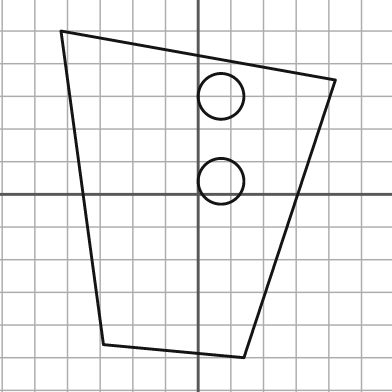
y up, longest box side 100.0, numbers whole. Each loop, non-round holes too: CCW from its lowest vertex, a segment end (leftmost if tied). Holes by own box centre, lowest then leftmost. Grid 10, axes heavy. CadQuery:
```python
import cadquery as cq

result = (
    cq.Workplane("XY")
    .moveTo(14.0, -50.0)
    .lineTo(42.0, 35.0)
    .lineTo(-42.0, 50.0)
    .lineTo(-29.0, -46.0)
    .close()
    .moveTo(7.0, 4.0)
    .circle(7.0)
    .moveTo(7.0, 30.0)
    .circle(7.0)
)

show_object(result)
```